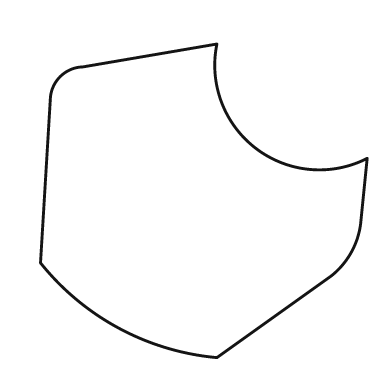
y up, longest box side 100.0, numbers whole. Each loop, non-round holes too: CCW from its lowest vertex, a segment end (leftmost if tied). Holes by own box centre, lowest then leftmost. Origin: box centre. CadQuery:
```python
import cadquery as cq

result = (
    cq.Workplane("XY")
    .moveTo(4.0, -48.0)
    .lineTo(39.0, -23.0)
    .threePointArc((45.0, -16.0), (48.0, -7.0))
    .lineTo(50.0, 13.0)
    .threePointArc((16.0, 16.0), (4.0, 48.0))
    .lineTo(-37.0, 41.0)
    .threePointArc((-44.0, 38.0), (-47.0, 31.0))
    .lineTo(-50.0, -19.0)
    .threePointArc((-26.0, -39.0), (4.0, -48.0))
    .close()
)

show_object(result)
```